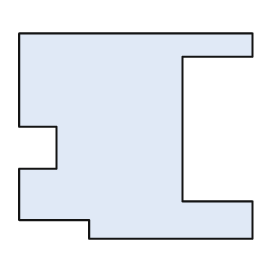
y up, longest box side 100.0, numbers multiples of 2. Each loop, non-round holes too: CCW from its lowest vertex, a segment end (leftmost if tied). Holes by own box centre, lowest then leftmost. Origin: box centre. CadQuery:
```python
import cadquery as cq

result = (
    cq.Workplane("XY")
    .moveTo(-20.0, -44.0)
    .lineTo(50.0, -44.0)
    .lineTo(50.0, -28.0)
    .lineTo(20.0, -28.0)
    .lineTo(20.0, 34.0)
    .lineTo(50.0, 34.0)
    .lineTo(50.0, 44.0)
    .lineTo(-50.0, 44.0)
    .lineTo(-50.0, 4.0)
    .lineTo(-34.0, 4.0)
    .lineTo(-34.0, -14.0)
    .lineTo(-50.0, -14.0)
    .lineTo(-50.0, -36.0)
    .lineTo(-20.0, -36.0)
    .close()
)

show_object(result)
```